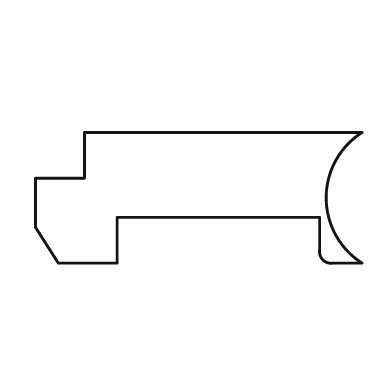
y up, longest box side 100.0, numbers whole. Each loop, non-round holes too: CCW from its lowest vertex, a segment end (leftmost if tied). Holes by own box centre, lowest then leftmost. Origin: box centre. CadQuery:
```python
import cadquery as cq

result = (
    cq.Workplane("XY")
    .moveTo(-43.0, -20.0)
    .lineTo(-25.0, -20.0)
    .lineTo(-25.0, -6.0)
    .lineTo(37.0, -6.0)
    .lineTo(37.0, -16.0)
    .threePointArc((38.0, -19.0), (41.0, -20.0))
    .lineTo(50.0, -20.0)
    .threePointArc((39.0, 0.0), (50.0, 20.0))
    .lineTo(-35.0, 20.0)
    .lineTo(-35.0, 6.0)
    .lineTo(-50.0, 6.0)
    .lineTo(-50.0, -9.0)
    .close()
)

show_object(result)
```